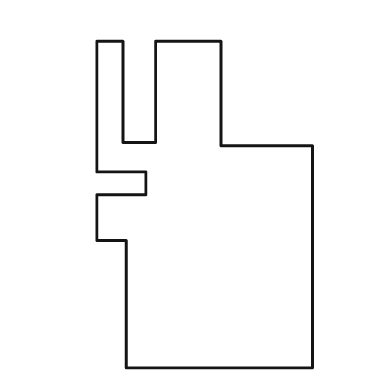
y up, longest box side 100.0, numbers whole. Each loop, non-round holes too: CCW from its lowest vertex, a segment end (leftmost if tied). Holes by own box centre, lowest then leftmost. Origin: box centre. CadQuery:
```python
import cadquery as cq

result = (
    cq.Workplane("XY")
    .moveTo(-24.0, -50.0)
    .lineTo(33.0, -50.0)
    .lineTo(33.0, 18.0)
    .lineTo(5.0, 18.0)
    .lineTo(5.0, 50.0)
    .lineTo(-15.0, 50.0)
    .lineTo(-15.0, 19.0)
    .lineTo(-25.0, 19.0)
    .lineTo(-25.0, 50.0)
    .lineTo(-33.0, 50.0)
    .lineTo(-33.0, 10.0)
    .lineTo(-18.0, 10.0)
    .lineTo(-18.0, 3.0)
    .lineTo(-33.0, 3.0)
    .lineTo(-33.0, -11.0)
    .lineTo(-24.0, -11.0)
    .close()
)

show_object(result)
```